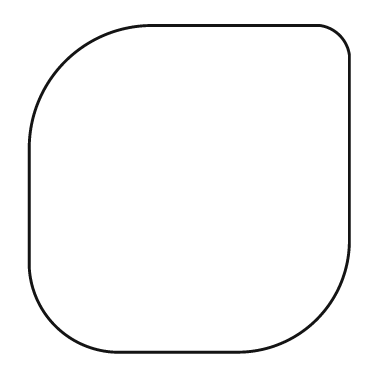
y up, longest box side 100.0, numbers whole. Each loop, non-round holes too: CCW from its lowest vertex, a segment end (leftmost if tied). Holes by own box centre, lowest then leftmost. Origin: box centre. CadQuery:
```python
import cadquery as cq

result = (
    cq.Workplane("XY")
    .moveTo(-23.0, -50.0)
    .lineTo(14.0, -50.0)
    .threePointArc((39.0, -40.0), (49.0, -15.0))
    .lineTo(49.0, 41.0)
    .threePointArc((46.0, 47.0), (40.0, 50.0))
    .lineTo(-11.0, 50.0)
    .threePointArc((-38.0, 39.0), (-49.0, 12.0))
    .lineTo(-49.0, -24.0)
    .threePointArc((-41.0, -42.0), (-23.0, -50.0))
    .close()
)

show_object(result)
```